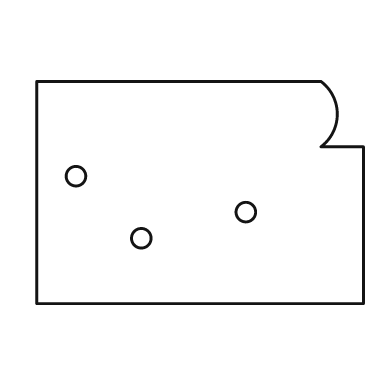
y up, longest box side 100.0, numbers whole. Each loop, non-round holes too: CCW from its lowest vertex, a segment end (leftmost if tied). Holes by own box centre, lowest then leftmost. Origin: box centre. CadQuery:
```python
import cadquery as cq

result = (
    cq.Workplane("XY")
    .moveTo(-50.0, -34.0)
    .lineTo(50.0, -34.0)
    .lineTo(50.0, 14.0)
    .lineTo(37.0, 14.0)
    .threePointArc((42.0, 24.0), (37.0, 34.0))
    .lineTo(-50.0, 34.0)
    .close()
    .moveTo(-18.0, -14.0)
    .circle(3.0)
    .moveTo(14.0, -6.0)
    .circle(3.0)
    .moveTo(-38.0, 5.0)
    .circle(3.0)
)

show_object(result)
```